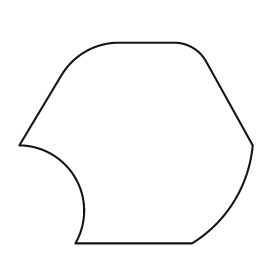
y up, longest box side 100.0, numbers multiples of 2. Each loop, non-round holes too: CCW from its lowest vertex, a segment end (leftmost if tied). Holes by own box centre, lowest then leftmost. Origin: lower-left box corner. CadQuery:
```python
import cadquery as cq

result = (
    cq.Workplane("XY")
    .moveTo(24.0, 0.0)
    .lineTo(74.0, 0.0)
    .threePointArc((92.0, 18.0), (100.0, 42.0))
    .lineTo(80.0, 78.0)
    .threePointArc((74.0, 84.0), (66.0, 86.0))
    .lineTo(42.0, 86.0)
    .threePointArc((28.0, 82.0), (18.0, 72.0))
    .lineTo(0.0, 42.0)
    .threePointArc((24.0, 28.0), (24.0, 0.0))
    .close()
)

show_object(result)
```